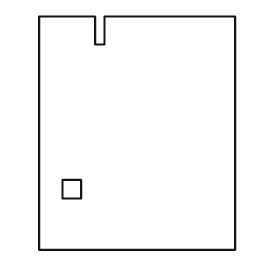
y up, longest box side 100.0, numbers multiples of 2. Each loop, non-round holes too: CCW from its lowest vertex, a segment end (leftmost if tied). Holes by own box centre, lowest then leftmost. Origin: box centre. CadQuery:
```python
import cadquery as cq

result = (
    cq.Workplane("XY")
    .moveTo(-42.0, -50.0)
    .lineTo(42.0, -50.0)
    .lineTo(42.0, 50.0)
    .lineTo(-14.0, 50.0)
    .lineTo(-14.0, 38.0)
    .lineTo(-18.0, 38.0)
    .lineTo(-18.0, 50.0)
    .lineTo(-42.0, 50.0)
    .close()
    .moveTo(-32.0, -28.0)
    .lineTo(-24.0, -28.0)
    .lineTo(-24.0, -20.0)
    .lineTo(-32.0, -20.0)
    .close()
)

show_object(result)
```